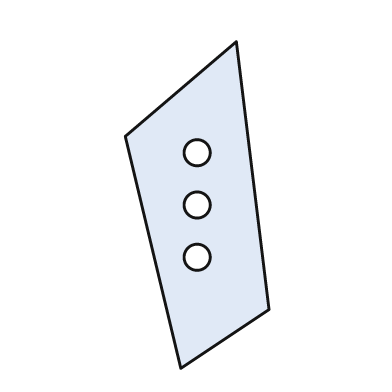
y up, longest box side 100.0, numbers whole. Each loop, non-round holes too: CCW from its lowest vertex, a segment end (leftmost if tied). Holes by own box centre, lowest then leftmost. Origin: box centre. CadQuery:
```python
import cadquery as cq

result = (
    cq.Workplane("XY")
    .moveTo(-5.0, -50.0)
    .lineTo(22.0, -32.0)
    .lineTo(12.0, 50.0)
    .lineTo(-22.0, 21.0)
    .close()
    .moveTo(0.0, -16.0)
    .circle(4.0)
    .moveTo(0.0, 0.0)
    .circle(4.0)
    .moveTo(0.0, 16.0)
    .circle(4.0)
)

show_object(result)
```